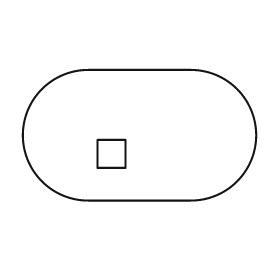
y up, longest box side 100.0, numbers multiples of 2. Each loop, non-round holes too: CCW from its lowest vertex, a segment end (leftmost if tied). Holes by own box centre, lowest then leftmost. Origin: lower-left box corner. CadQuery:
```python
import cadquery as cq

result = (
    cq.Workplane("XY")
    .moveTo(28.0, 0.0)
    .lineTo(72.0, 0.0)
    .threePointArc((100.0, 28.0), (72.0, 56.0))
    .lineTo(28.0, 56.0)
    .threePointArc((0.0, 28.0), (28.0, 0.0))
    .close()
    .moveTo(32.0, 14.0)
    .lineTo(44.0, 14.0)
    .lineTo(44.0, 26.0)
    .lineTo(32.0, 26.0)
    .close()
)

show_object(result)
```